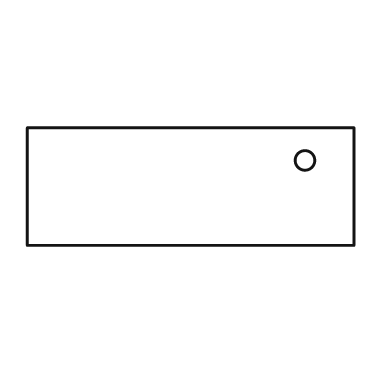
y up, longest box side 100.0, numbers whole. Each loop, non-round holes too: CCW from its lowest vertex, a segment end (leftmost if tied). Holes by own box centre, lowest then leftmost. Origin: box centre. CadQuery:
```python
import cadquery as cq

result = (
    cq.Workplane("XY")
    .moveTo(-50.0, -18.0)
    .lineTo(50.0, -18.0)
    .lineTo(50.0, 18.0)
    .lineTo(-50.0, 18.0)
    .close()
    .moveTo(35.0, 8.0)
    .circle(3.0)
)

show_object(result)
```